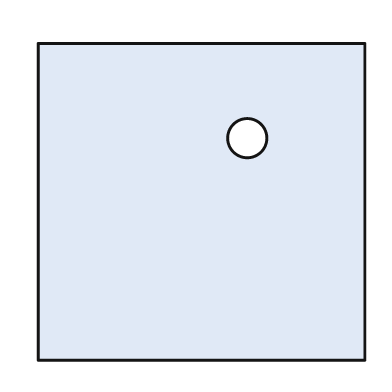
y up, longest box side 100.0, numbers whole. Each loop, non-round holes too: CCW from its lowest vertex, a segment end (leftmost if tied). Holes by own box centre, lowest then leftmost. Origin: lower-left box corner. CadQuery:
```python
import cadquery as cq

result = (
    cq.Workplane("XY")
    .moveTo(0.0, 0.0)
    .lineTo(100.0, 0.0)
    .lineTo(100.0, 97.0)
    .lineTo(0.0, 97.0)
    .close()
    .moveTo(64.0, 68.0)
    .circle(6.0)
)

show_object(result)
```